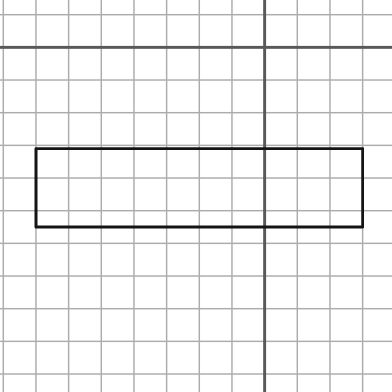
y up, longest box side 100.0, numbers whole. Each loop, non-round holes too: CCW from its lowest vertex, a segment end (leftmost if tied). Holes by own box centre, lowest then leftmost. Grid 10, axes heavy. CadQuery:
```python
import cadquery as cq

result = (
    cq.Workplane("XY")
    .moveTo(-70.0, -55.0)
    .lineTo(30.0, -55.0)
    .lineTo(30.0, -31.0)
    .lineTo(-70.0, -31.0)
    .close()
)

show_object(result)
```